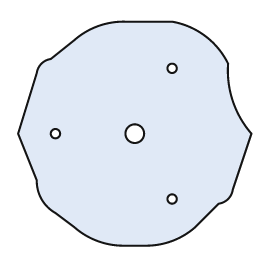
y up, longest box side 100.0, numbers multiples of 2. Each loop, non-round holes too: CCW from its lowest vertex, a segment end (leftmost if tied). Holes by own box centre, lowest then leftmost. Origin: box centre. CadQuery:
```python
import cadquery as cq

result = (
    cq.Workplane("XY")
    .moveTo(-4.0, -48.0)
    .lineTo(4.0, -48.0)
    .threePointArc((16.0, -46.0), (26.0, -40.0))
    .lineTo(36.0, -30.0)
    .threePointArc((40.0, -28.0), (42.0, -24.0))
    .lineTo(50.0, 0.0)
    .threePointArc((42.0, 14.0), (40.0, 30.0))
    .threePointArc((30.0, 42.0), (16.0, 48.0))
    .lineTo(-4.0, 48.0)
    .threePointArc((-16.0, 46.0), (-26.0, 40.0))
    .lineTo(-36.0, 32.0)
    .threePointArc((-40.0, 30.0), (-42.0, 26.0))
    .lineTo(-50.0, 0.0)
    .lineTo(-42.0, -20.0)
    .threePointArc((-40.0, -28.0), (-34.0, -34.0))
    .lineTo(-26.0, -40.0)
    .threePointArc((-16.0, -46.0), (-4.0, -48.0))
    .close()
    .moveTo(16.0, -28.0)
    .circle(2.0)
    .moveTo(-34.0, 0.0)
    .circle(2.0)
    .moveTo(0.0, 0.0)
    .circle(4.0)
    .moveTo(16.0, 28.0)
    .circle(2.0)
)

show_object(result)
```